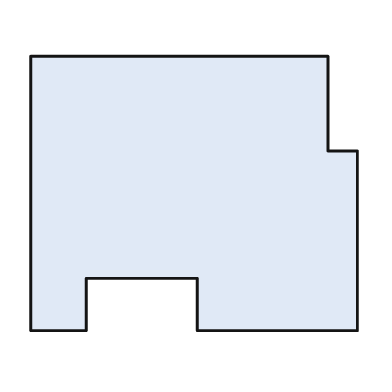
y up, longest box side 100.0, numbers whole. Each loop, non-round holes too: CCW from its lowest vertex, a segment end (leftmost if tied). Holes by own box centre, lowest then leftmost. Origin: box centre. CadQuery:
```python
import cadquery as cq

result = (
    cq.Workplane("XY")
    .moveTo(-50.0, -42.0)
    .lineTo(-33.0, -42.0)
    .lineTo(-33.0, -26.0)
    .lineTo(1.0, -26.0)
    .lineTo(1.0, -42.0)
    .lineTo(50.0, -42.0)
    .lineTo(50.0, 13.0)
    .lineTo(41.0, 13.0)
    .lineTo(41.0, 42.0)
    .lineTo(-50.0, 42.0)
    .close()
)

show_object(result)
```